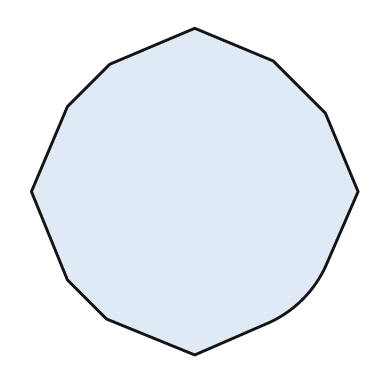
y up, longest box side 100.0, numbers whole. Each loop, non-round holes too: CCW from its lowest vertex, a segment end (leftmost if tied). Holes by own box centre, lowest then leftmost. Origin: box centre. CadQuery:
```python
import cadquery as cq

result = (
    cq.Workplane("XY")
    .moveTo(0.0, -50.0)
    .lineTo(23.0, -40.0)
    .threePointArc((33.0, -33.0), (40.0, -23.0))
    .lineTo(50.0, 0.0)
    .lineTo(40.0, 24.0)
    .lineTo(24.0, 40.0)
    .lineTo(0.0, 50.0)
    .lineTo(-26.0, 39.0)
    .lineTo(-39.0, 26.0)
    .lineTo(-50.0, 0.0)
    .lineTo(-39.0, -27.0)
    .lineTo(-27.0, -39.0)
    .close()
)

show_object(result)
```